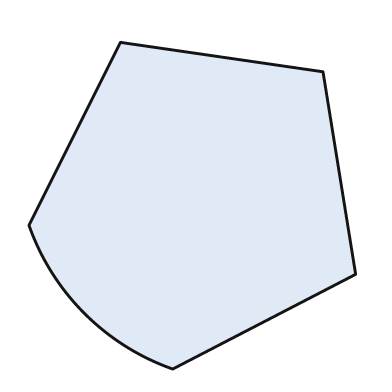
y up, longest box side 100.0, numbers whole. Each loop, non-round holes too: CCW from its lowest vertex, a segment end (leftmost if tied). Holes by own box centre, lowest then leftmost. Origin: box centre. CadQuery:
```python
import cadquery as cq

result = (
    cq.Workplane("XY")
    .moveTo(-6.0, -50.0)
    .lineTo(50.0, -21.0)
    .lineTo(40.0, 41.0)
    .lineTo(-22.0, 50.0)
    .lineTo(-50.0, -6.0)
    .threePointArc((-33.0, -33.0), (-6.0, -50.0))
    .close()
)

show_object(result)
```